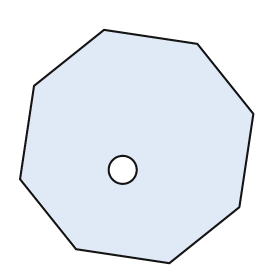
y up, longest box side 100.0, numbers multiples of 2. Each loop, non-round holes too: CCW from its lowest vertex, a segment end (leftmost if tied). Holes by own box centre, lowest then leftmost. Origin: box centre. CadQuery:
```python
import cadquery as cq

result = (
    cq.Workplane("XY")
    .moveTo(14.0, -50.0)
    .lineTo(44.0, -26.0)
    .lineTo(50.0, 14.0)
    .lineTo(26.0, 44.0)
    .lineTo(-14.0, 50.0)
    .lineTo(-44.0, 26.0)
    .lineTo(-50.0, -14.0)
    .lineTo(-26.0, -44.0)
    .close()
    .moveTo(-6.0, -10.0)
    .circle(6.0)
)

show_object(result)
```